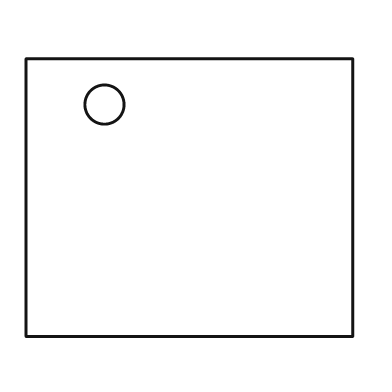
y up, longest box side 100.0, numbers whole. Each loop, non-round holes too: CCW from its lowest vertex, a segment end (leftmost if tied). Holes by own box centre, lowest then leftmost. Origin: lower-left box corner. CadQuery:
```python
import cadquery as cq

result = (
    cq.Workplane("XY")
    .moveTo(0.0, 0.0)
    .lineTo(100.0, 0.0)
    .lineTo(100.0, 85.0)
    .lineTo(0.0, 85.0)
    .close()
    .moveTo(24.0, 71.0)
    .circle(6.0)
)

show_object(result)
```